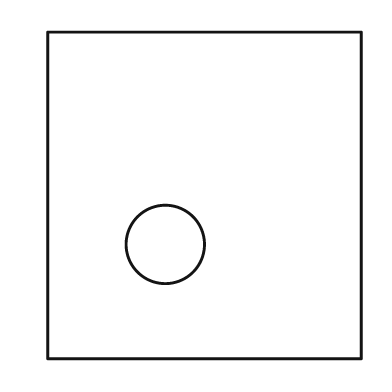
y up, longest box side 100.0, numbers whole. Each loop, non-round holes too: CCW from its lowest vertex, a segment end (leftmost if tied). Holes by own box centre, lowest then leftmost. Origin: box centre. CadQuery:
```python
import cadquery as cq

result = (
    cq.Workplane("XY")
    .moveTo(-48.0, -50.0)
    .lineTo(48.0, -50.0)
    .lineTo(48.0, 50.0)
    .lineTo(-48.0, 50.0)
    .close()
    .moveTo(-12.0, -15.0)
    .circle(12.0)
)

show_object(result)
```